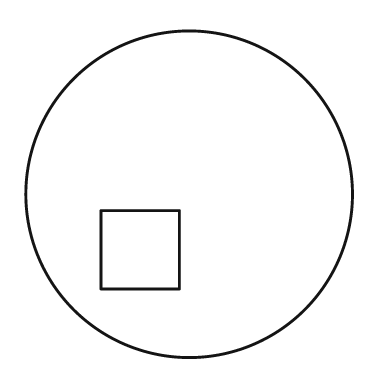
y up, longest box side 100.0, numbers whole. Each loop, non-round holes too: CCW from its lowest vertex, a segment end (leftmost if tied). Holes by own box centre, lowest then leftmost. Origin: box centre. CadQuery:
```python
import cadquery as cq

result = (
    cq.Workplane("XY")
    .moveTo(0.0, 0.0)
    .circle(50.0)
    .moveTo(-27.0, -29.0)
    .lineTo(-3.0, -29.0)
    .lineTo(-3.0, -5.0)
    .lineTo(-27.0, -5.0)
    .close()
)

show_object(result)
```